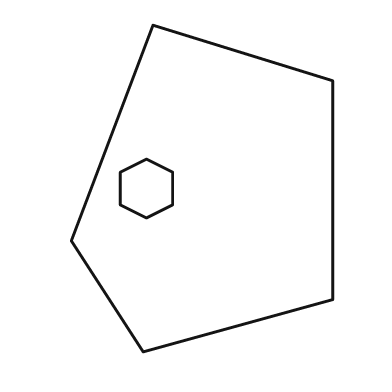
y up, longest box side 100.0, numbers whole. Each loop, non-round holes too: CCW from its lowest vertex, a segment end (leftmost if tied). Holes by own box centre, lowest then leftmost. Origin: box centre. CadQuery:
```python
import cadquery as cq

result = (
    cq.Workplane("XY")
    .moveTo(-18.0, -50.0)
    .lineTo(40.0, -34.0)
    .lineTo(40.0, 33.0)
    .lineTo(-15.0, 50.0)
    .lineTo(-40.0, -16.0)
    .close()
    .moveTo(-17.0, -9.0)
    .lineTo(-9.0, -5.0)
    .lineTo(-9.0, 5.0)
    .lineTo(-17.0, 9.0)
    .lineTo(-25.0, 5.0)
    .lineTo(-25.0, -5.0)
    .close()
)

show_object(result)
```